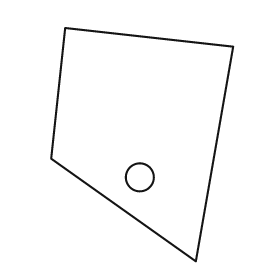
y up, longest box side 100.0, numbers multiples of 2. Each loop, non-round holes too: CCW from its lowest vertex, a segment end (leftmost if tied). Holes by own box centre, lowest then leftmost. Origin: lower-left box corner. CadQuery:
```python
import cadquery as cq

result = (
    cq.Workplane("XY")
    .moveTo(62.0, 0.0)
    .lineTo(78.0, 92.0)
    .lineTo(6.0, 100.0)
    .lineTo(0.0, 44.0)
    .close()
    .moveTo(38.0, 36.0)
    .circle(6.0)
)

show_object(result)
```